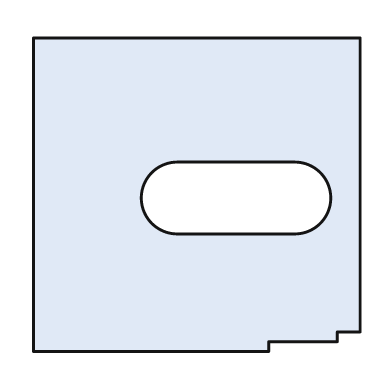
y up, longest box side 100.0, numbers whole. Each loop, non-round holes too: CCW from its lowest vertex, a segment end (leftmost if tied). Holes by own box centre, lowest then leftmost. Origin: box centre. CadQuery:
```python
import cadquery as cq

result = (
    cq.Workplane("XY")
    .moveTo(-50.0, -48.0)
    .lineTo(22.0, -48.0)
    .lineTo(22.0, -45.0)
    .lineTo(43.0, -45.0)
    .lineTo(43.0, -42.0)
    .lineTo(50.0, -42.0)
    .lineTo(50.0, 48.0)
    .lineTo(-50.0, 48.0)
    .close()
    .moveTo(-6.0, -12.0)
    .lineTo(30.0, -12.0)
    .threePointArc((41.0, -1.0), (30.0, 10.0))
    .lineTo(-6.0, 10.0)
    .threePointArc((-17.0, -1.0), (-6.0, -12.0))
    .close()
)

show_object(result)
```